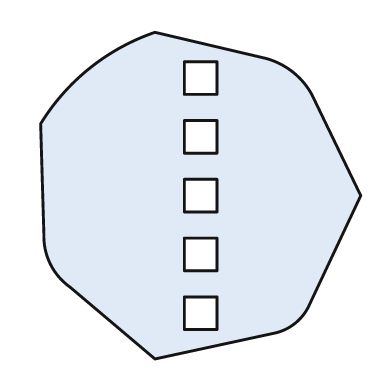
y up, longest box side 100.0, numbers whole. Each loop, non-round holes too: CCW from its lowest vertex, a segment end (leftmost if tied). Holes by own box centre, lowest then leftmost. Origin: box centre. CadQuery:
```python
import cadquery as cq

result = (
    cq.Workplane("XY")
    .moveTo(-14.0, -50.0)
    .lineTo(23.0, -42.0)
    .threePointArc((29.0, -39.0), (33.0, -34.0))
    .lineTo(49.0, 0.0)
    .lineTo(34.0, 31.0)
    .threePointArc((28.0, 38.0), (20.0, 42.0))
    .lineTo(-14.0, 50.0)
    .threePointArc((-34.0, 39.0), (-49.0, 22.0))
    .lineTo(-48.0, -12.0)
    .threePointArc((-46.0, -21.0), (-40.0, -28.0))
    .close()
    .moveTo(-5.0, -41.0)
    .lineTo(5.0, -41.0)
    .lineTo(5.0, -31.0)
    .lineTo(-5.0, -31.0)
    .close()
    .moveTo(-5.0, -23.0)
    .lineTo(5.0, -23.0)
    .lineTo(5.0, -13.0)
    .lineTo(-5.0, -13.0)
    .close()
    .moveTo(-5.0, -5.0)
    .lineTo(5.0, -5.0)
    .lineTo(5.0, 5.0)
    .lineTo(-5.0, 5.0)
    .close()
    .moveTo(-5.0, 13.0)
    .lineTo(5.0, 13.0)
    .lineTo(5.0, 23.0)
    .lineTo(-5.0, 23.0)
    .close()
    .moveTo(-5.0, 31.0)
    .lineTo(5.0, 31.0)
    .lineTo(5.0, 41.0)
    .lineTo(-5.0, 41.0)
    .close()
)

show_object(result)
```